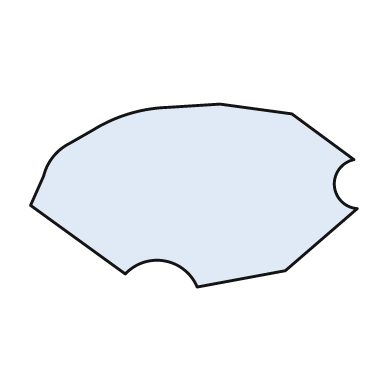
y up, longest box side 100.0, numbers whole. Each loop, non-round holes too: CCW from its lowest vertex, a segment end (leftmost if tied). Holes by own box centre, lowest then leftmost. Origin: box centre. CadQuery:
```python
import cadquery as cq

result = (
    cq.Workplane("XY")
    .moveTo(1.0, -28.0)
    .lineTo(28.0, -23.0)
    .lineTo(50.0, -4.0)
    .threePointArc((43.0, 3.0), (49.0, 11.0))
    .lineTo(30.0, 25.0)
    .lineTo(8.0, 28.0)
    .lineTo(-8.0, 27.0)
    .threePointArc((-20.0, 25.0), (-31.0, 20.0))
    .lineTo(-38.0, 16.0)
    .threePointArc((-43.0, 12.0), (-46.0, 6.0))
    .lineTo(-50.0, -3.0)
    .lineTo(-21.0, -24.0)
    .threePointArc((-9.0, -20.0), (1.0, -28.0))
    .close()
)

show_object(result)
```